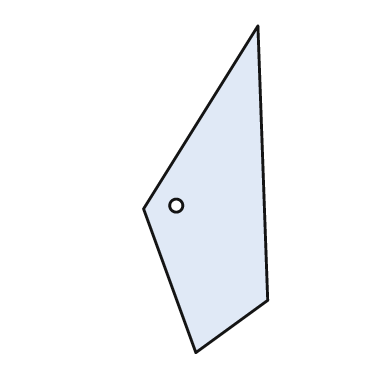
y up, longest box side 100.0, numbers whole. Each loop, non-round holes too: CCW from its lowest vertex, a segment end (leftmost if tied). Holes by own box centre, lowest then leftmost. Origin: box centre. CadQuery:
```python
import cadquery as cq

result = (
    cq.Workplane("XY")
    .moveTo(-3.0, -50.0)
    .lineTo(19.0, -34.0)
    .lineTo(16.0, 50.0)
    .lineTo(-19.0, -6.0)
    .close()
    .moveTo(-9.0, -5.0)
    .circle(2.0)
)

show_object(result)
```